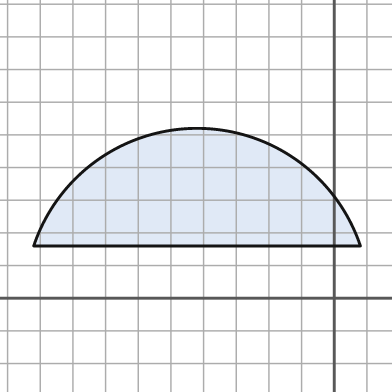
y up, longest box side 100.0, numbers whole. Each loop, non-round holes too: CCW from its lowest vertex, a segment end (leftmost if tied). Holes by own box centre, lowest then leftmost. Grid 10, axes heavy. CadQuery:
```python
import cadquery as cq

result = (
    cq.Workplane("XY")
    .moveTo(-92.0, 16.0)
    .lineTo(8.0, 16.0)
    .threePointArc((-42.0, 52.0), (-92.0, 16.0))
    .close()
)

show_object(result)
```